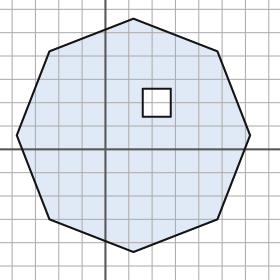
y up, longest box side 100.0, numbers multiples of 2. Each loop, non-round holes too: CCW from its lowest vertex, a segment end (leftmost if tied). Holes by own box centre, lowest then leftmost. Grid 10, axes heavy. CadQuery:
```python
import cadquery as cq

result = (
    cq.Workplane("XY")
    .moveTo(12.0, -44.0)
    .lineTo(48.0, -30.0)
    .lineTo(62.0, 6.0)
    .lineTo(48.0, 42.0)
    .lineTo(12.0, 56.0)
    .lineTo(-24.0, 42.0)
    .lineTo(-38.0, 6.0)
    .lineTo(-24.0, -30.0)
    .close()
    .moveTo(16.0, 14.0)
    .lineTo(28.0, 14.0)
    .lineTo(28.0, 26.0)
    .lineTo(16.0, 26.0)
    .close()
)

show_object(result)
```